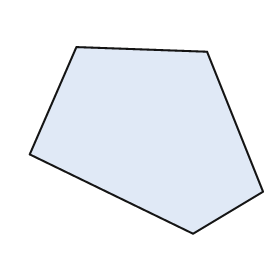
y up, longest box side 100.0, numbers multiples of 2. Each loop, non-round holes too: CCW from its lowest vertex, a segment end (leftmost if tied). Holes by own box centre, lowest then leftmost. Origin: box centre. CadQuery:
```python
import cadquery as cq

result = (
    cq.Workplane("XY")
    .moveTo(20.0, -40.0)
    .lineTo(50.0, -22.0)
    .lineTo(26.0, 38.0)
    .lineTo(-30.0, 40.0)
    .lineTo(-50.0, -6.0)
    .close()
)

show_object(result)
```